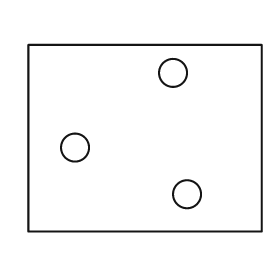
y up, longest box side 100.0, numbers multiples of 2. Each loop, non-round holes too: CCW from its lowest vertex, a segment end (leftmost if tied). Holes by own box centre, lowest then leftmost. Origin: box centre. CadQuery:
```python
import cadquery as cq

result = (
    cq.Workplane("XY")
    .moveTo(-50.0, -40.0)
    .lineTo(50.0, -40.0)
    .lineTo(50.0, 40.0)
    .lineTo(-50.0, 40.0)
    .close()
    .moveTo(18.0, -24.0)
    .circle(6.0)
    .moveTo(-30.0, -4.0)
    .circle(6.0)
    .moveTo(12.0, 28.0)
    .circle(6.0)
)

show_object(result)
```